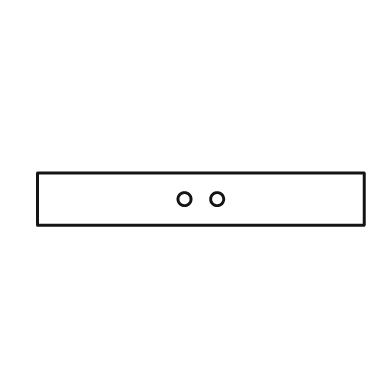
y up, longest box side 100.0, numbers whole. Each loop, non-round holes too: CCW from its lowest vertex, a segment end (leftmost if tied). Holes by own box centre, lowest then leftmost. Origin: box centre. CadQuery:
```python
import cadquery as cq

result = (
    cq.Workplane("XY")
    .moveTo(-50.0, -8.0)
    .lineTo(50.0, -8.0)
    .lineTo(50.0, 8.0)
    .lineTo(-50.0, 8.0)
    .close()
    .moveTo(-5.0, 0.0)
    .circle(2.0)
    .moveTo(5.0, 0.0)
    .circle(2.0)
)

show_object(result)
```